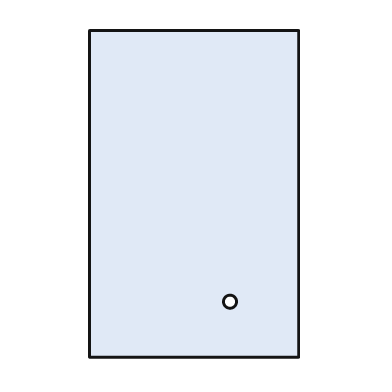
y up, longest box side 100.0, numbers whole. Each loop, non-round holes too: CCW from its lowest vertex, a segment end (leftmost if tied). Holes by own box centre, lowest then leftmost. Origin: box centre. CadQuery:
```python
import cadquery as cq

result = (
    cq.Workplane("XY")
    .moveTo(-32.0, -50.0)
    .lineTo(32.0, -50.0)
    .lineTo(32.0, 50.0)
    .lineTo(-32.0, 50.0)
    .close()
    .moveTo(11.0, -33.0)
    .circle(2.0)
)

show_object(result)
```